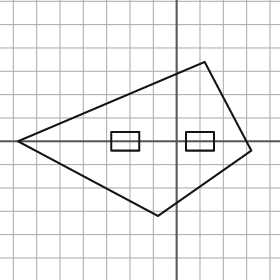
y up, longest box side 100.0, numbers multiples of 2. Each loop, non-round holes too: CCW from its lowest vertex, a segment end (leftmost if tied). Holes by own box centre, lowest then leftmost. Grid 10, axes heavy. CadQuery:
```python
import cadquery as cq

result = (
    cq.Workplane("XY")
    .moveTo(-8.0, -32.0)
    .lineTo(32.0, -4.0)
    .lineTo(12.0, 34.0)
    .lineTo(-68.0, 0.0)
    .close()
    .moveTo(-28.0, -4.0)
    .lineTo(-16.0, -4.0)
    .lineTo(-16.0, 4.0)
    .lineTo(-28.0, 4.0)
    .close()
    .moveTo(4.0, -4.0)
    .lineTo(16.0, -4.0)
    .lineTo(16.0, 4.0)
    .lineTo(4.0, 4.0)
    .close()
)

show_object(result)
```